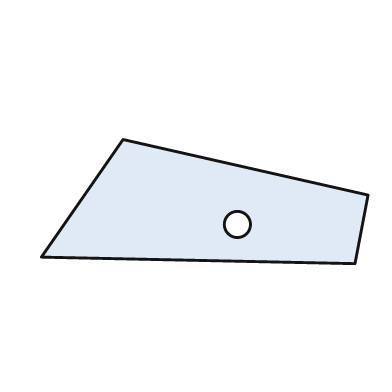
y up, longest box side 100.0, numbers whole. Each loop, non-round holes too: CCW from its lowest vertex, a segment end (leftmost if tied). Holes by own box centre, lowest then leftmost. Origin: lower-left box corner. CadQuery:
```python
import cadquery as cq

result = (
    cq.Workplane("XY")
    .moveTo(96.0, 0.0)
    .lineTo(100.0, 21.0)
    .lineTo(25.0, 38.0)
    .lineTo(0.0, 2.0)
    .close()
    .moveTo(60.0, 12.0)
    .circle(4.0)
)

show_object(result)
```